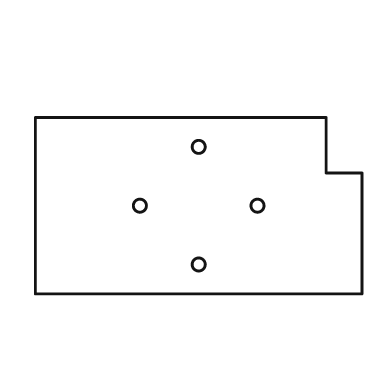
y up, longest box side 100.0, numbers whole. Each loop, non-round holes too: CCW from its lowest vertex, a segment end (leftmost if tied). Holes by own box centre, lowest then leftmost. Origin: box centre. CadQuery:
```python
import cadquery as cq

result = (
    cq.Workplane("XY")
    .moveTo(-50.0, -27.0)
    .lineTo(50.0, -27.0)
    .lineTo(50.0, 10.0)
    .lineTo(39.0, 10.0)
    .lineTo(39.0, 27.0)
    .lineTo(-50.0, 27.0)
    .close()
    .moveTo(0.0, -18.0)
    .circle(2.0)
    .moveTo(-18.0, 0.0)
    .circle(2.0)
    .moveTo(18.0, 0.0)
    .circle(2.0)
    .moveTo(0.0, 18.0)
    .circle(2.0)
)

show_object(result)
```